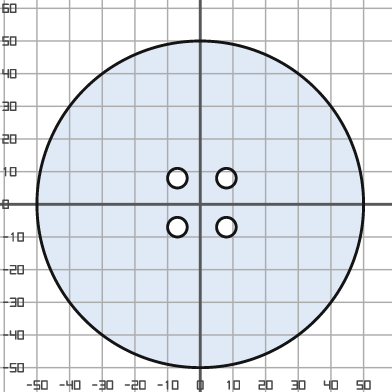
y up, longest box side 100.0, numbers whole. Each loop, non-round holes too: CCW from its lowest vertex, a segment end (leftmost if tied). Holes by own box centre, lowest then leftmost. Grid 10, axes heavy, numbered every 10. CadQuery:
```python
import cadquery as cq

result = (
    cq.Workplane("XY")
    .moveTo(0.0, 0.0)
    .circle(50.0)
    .moveTo(-7.0, -7.0)
    .circle(3.0)
    .moveTo(8.0, -7.0)
    .circle(3.0)
    .moveTo(-7.0, 8.0)
    .circle(3.0)
    .moveTo(8.0, 8.0)
    .circle(3.0)
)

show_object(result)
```